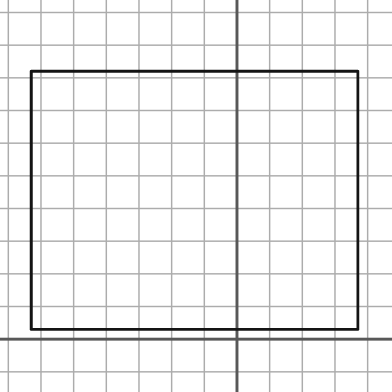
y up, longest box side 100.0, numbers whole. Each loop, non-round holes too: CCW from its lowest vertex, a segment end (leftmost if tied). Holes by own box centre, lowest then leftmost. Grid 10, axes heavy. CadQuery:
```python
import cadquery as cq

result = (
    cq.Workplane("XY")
    .moveTo(-63.0, 3.0)
    .lineTo(37.0, 3.0)
    .lineTo(37.0, 82.0)
    .lineTo(-63.0, 82.0)
    .close()
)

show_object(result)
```